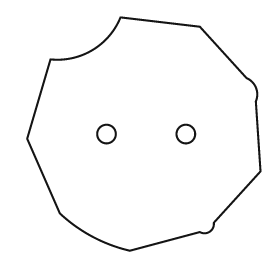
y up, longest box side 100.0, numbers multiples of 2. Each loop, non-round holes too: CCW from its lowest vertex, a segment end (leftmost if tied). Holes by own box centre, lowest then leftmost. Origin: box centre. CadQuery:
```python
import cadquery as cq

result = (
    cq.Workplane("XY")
    .moveTo(-6.0, -50.0)
    .lineTo(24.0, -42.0)
    .threePointArc((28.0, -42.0), (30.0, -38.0))
    .lineTo(50.0, -16.0)
    .lineTo(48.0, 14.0)
    .threePointArc((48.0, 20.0), (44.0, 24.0))
    .lineTo(24.0, 46.0)
    .lineTo(-10.0, 50.0)
    .threePointArc((-22.0, 36.0), (-40.0, 32.0))
    .lineTo(-50.0, -2.0)
    .lineTo(-36.0, -34.0)
    .threePointArc((-22.0, -44.0), (-6.0, -50.0))
    .close()
    .moveTo(-16.0, 0.0)
    .circle(4.0)
    .moveTo(18.0, 0.0)
    .circle(4.0)
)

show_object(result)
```